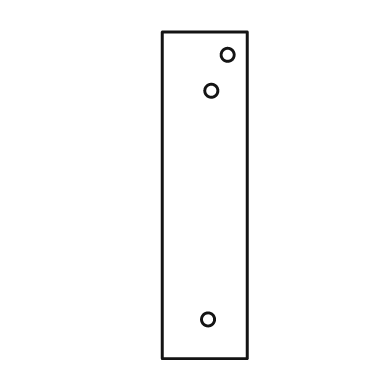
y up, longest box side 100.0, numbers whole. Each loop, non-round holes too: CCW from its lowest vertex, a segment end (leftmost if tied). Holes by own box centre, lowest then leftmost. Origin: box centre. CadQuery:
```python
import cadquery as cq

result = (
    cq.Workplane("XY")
    .moveTo(-13.0, -50.0)
    .lineTo(13.0, -50.0)
    .lineTo(13.0, 50.0)
    .lineTo(-13.0, 50.0)
    .close()
    .moveTo(1.0, -38.0)
    .circle(2.0)
    .moveTo(2.0, 32.0)
    .circle(2.0)
    .moveTo(7.0, 43.0)
    .circle(2.0)
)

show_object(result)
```